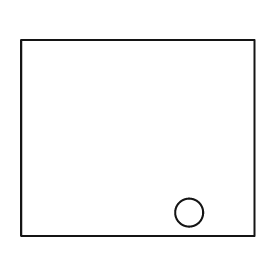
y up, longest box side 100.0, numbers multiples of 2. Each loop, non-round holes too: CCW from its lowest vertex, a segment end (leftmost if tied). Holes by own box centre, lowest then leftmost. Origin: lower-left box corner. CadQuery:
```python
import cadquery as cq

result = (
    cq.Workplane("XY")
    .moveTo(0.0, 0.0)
    .lineTo(100.0, 0.0)
    .lineTo(100.0, 84.0)
    .lineTo(0.0, 84.0)
    .close()
    .moveTo(72.0, 10.0)
    .circle(6.0)
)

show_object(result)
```